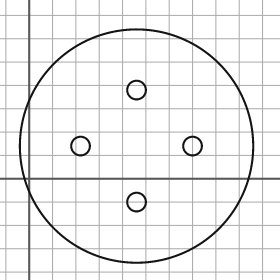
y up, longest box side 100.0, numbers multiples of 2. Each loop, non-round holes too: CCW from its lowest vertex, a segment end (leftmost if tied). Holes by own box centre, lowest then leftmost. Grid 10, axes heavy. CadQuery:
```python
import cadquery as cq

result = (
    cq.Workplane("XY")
    .moveTo(46.0, 14.0)
    .circle(50.0)
    .moveTo(46.0, -10.0)
    .circle(4.0)
    .moveTo(22.0, 14.0)
    .circle(4.0)
    .moveTo(70.0, 14.0)
    .circle(4.0)
    .moveTo(46.0, 38.0)
    .circle(4.0)
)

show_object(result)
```